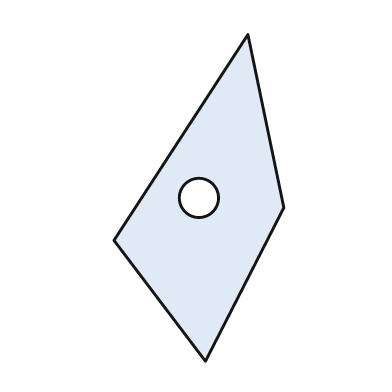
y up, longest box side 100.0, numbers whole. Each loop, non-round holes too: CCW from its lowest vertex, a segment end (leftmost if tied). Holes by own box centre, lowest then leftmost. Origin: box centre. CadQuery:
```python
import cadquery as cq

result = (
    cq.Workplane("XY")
    .moveTo(2.0, -50.0)
    .lineTo(26.0, -3.0)
    .lineTo(15.0, 50.0)
    .lineTo(-26.0, -13.0)
    .close()
    .moveTo(0.0, 0.0)
    .circle(6.0)
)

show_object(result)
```